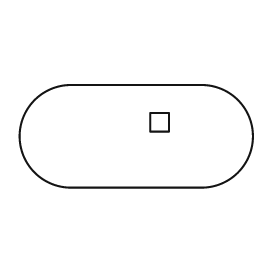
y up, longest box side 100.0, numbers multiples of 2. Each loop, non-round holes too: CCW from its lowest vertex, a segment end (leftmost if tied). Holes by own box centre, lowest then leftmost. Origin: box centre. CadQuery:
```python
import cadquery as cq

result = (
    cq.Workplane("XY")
    .moveTo(-28.0, -22.0)
    .lineTo(28.0, -22.0)
    .threePointArc((50.0, 0.0), (28.0, 22.0))
    .lineTo(-28.0, 22.0)
    .threePointArc((-50.0, 0.0), (-28.0, -22.0))
    .close()
    .moveTo(6.0, 2.0)
    .lineTo(14.0, 2.0)
    .lineTo(14.0, 10.0)
    .lineTo(6.0, 10.0)
    .close()
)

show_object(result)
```